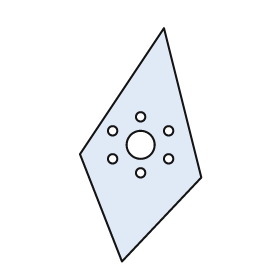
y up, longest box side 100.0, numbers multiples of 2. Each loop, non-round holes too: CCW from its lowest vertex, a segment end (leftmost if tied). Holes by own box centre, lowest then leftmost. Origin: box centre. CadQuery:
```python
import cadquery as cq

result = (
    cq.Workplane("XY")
    .moveTo(-8.0, -50.0)
    .lineTo(26.0, -14.0)
    .lineTo(10.0, 50.0)
    .lineTo(-26.0, -4.0)
    .close()
    .moveTo(0.0, -12.0)
    .circle(2.0)
    .moveTo(-12.0, -6.0)
    .circle(2.0)
    .moveTo(12.0, -6.0)
    .circle(2.0)
    .moveTo(0.0, 0.0)
    .circle(6.0)
    .moveTo(-12.0, 6.0)
    .circle(2.0)
    .moveTo(12.0, 6.0)
    .circle(2.0)
    .moveTo(0.0, 12.0)
    .circle(2.0)
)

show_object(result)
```